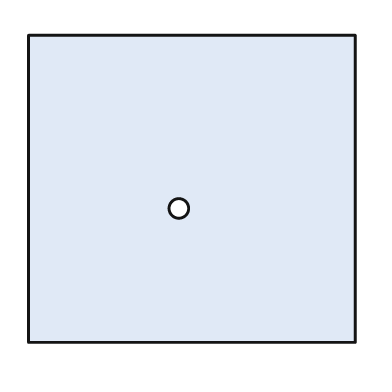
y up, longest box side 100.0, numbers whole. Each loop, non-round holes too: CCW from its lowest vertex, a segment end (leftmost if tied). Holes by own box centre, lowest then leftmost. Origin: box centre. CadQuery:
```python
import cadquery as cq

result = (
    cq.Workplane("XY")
    .moveTo(-50.0, -47.0)
    .lineTo(50.0, -47.0)
    .lineTo(50.0, 47.0)
    .lineTo(-50.0, 47.0)
    .close()
    .moveTo(-4.0, -6.0)
    .circle(3.0)
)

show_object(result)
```